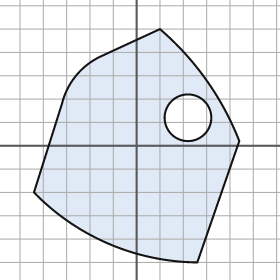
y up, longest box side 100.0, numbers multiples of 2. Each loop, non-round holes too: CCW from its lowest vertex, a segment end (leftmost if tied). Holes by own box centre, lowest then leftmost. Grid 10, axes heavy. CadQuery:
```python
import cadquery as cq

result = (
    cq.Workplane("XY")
    .moveTo(26.0, -50.0)
    .lineTo(44.0, 2.0)
    .threePointArc((30.0, 28.0), (10.0, 50.0))
    .lineTo(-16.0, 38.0)
    .threePointArc((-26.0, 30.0), (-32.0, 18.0))
    .lineTo(-44.0, -20.0)
    .threePointArc((-12.0, -42.0), (26.0, -50.0))
    .close()
    .moveTo(22.0, 12.0)
    .circle(10.0)
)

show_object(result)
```